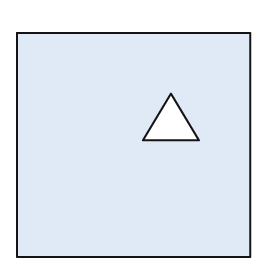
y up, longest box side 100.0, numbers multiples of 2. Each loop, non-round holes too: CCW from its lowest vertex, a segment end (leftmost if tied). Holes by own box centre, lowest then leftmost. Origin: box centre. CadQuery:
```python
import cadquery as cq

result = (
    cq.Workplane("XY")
    .moveTo(-50.0, -48.0)
    .lineTo(50.0, -48.0)
    .lineTo(50.0, 48.0)
    .lineTo(-50.0, 48.0)
    .close()
    .moveTo(4.0, 2.0)
    .lineTo(28.0, 2.0)
    .lineTo(16.0, 22.0)
    .close()
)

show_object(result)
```